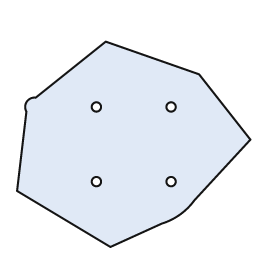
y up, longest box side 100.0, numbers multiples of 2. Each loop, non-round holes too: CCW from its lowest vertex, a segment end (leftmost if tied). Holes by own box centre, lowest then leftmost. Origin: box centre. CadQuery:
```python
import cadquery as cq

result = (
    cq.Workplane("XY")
    .moveTo(-10.0, -44.0)
    .lineTo(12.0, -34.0)
    .threePointArc((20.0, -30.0), (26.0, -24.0))
    .lineTo(50.0, 2.0)
    .lineTo(28.0, 30.0)
    .lineTo(-12.0, 44.0)
    .lineTo(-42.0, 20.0)
    .threePointArc((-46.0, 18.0), (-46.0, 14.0))
    .lineTo(-50.0, -20.0)
    .close()
    .moveTo(-16.0, -16.0)
    .circle(2.0)
    .moveTo(16.0, -16.0)
    .circle(2.0)
    .moveTo(-16.0, 16.0)
    .circle(2.0)
    .moveTo(16.0, 16.0)
    .circle(2.0)
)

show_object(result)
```